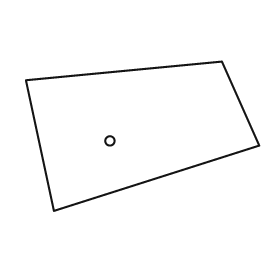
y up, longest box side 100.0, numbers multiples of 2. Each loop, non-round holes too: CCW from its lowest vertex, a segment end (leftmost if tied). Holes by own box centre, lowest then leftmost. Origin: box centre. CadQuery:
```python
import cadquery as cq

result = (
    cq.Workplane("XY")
    .moveTo(-38.0, -32.0)
    .lineTo(50.0, -4.0)
    .lineTo(34.0, 32.0)
    .lineTo(-50.0, 24.0)
    .close()
    .moveTo(-14.0, -2.0)
    .circle(2.0)
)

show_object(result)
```